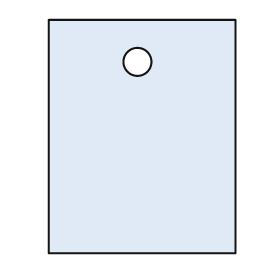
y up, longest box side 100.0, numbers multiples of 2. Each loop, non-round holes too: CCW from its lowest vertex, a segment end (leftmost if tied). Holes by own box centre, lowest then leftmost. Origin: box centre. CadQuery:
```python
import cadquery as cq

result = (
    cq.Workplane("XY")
    .moveTo(-40.0, -50.0)
    .lineTo(40.0, -50.0)
    .lineTo(40.0, 50.0)
    .lineTo(-40.0, 50.0)
    .close()
    .moveTo(-2.0, 32.0)
    .circle(6.0)
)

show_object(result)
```